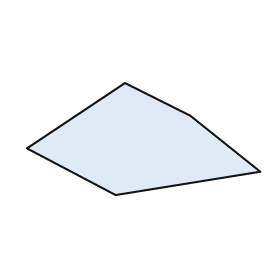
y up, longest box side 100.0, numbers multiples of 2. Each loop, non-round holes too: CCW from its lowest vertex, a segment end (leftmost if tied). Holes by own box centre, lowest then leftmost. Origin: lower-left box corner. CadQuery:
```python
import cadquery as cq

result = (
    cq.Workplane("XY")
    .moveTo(38.0, 0.0)
    .lineTo(100.0, 10.0)
    .lineTo(70.0, 34.0)
    .lineTo(42.0, 48.0)
    .lineTo(0.0, 20.0)
    .close()
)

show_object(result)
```